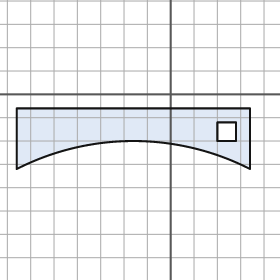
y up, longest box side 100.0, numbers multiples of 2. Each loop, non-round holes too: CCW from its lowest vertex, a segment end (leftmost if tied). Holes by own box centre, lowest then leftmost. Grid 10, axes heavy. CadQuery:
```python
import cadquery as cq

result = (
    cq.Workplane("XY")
    .moveTo(-66.0, -32.0)
    .threePointArc((-16.0, -20.0), (34.0, -32.0))
    .lineTo(34.0, -6.0)
    .lineTo(-66.0, -6.0)
    .close()
    .moveTo(20.0, -20.0)
    .lineTo(28.0, -20.0)
    .lineTo(28.0, -12.0)
    .lineTo(20.0, -12.0)
    .close()
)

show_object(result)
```